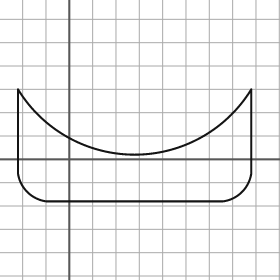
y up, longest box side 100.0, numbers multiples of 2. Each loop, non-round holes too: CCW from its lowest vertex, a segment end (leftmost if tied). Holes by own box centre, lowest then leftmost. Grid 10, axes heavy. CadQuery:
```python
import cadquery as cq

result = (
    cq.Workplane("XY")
    .moveTo(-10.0, -18.0)
    .lineTo(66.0, -18.0)
    .threePointArc((74.0, -14.0), (78.0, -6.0))
    .lineTo(78.0, 30.0)
    .threePointArc((28.0, 2.0), (-22.0, 30.0))
    .lineTo(-22.0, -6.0)
    .threePointArc((-18.0, -14.0), (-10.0, -18.0))
    .close()
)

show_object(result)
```